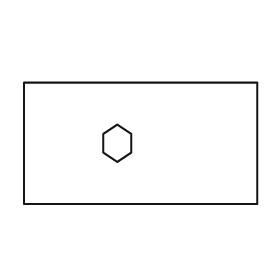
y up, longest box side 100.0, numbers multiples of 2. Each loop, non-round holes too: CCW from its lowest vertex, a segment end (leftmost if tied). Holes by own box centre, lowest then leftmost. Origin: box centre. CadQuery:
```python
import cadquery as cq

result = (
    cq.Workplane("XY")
    .moveTo(-50.0, -26.0)
    .lineTo(50.0, -26.0)
    .lineTo(50.0, 26.0)
    .lineTo(-50.0, 26.0)
    .close()
    .moveTo(-10.0, -8.0)
    .lineTo(-4.0, -4.0)
    .lineTo(-4.0, 4.0)
    .lineTo(-10.0, 8.0)
    .lineTo(-16.0, 4.0)
    .lineTo(-16.0, -4.0)
    .close()
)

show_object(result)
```